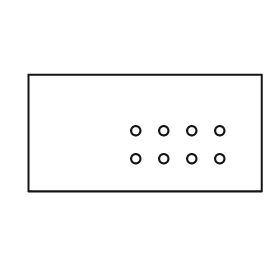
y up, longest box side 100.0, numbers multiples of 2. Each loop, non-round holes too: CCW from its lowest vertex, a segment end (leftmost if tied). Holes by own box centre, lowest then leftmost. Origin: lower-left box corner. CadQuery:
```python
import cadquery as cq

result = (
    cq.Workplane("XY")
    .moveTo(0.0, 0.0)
    .lineTo(100.0, 0.0)
    .lineTo(100.0, 50.0)
    .lineTo(0.0, 50.0)
    .close()
    .moveTo(46.0, 14.0)
    .circle(2.0)
    .moveTo(58.0, 14.0)
    .circle(2.0)
    .moveTo(70.0, 14.0)
    .circle(2.0)
    .moveTo(82.0, 14.0)
    .circle(2.0)
    .moveTo(46.0, 26.0)
    .circle(2.0)
    .moveTo(58.0, 26.0)
    .circle(2.0)
    .moveTo(70.0, 26.0)
    .circle(2.0)
    .moveTo(82.0, 26.0)
    .circle(2.0)
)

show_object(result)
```